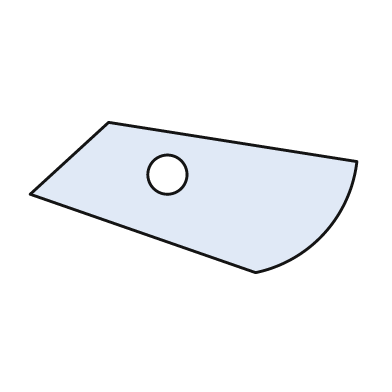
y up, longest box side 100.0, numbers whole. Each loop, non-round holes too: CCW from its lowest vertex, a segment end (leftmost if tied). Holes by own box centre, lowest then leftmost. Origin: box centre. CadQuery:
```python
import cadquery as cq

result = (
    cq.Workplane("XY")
    .moveTo(19.0, -23.0)
    .threePointArc((40.0, -11.0), (50.0, 11.0))
    .lineTo(-26.0, 23.0)
    .lineTo(-50.0, 1.0)
    .close()
    .moveTo(-8.0, 7.0)
    .circle(6.0)
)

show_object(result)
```